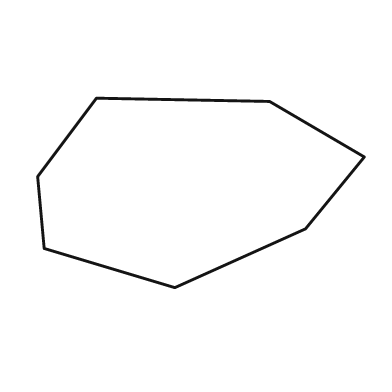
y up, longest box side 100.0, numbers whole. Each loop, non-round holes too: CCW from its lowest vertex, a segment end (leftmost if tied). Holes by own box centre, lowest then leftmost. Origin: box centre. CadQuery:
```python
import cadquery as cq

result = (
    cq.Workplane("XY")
    .moveTo(-8.0, -29.0)
    .lineTo(32.0, -11.0)
    .lineTo(50.0, 11.0)
    .lineTo(21.0, 28.0)
    .lineTo(-32.0, 29.0)
    .lineTo(-50.0, 5.0)
    .lineTo(-48.0, -17.0)
    .close()
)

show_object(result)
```